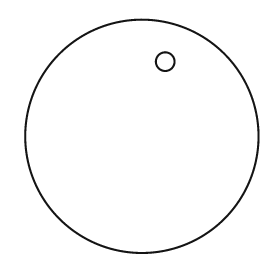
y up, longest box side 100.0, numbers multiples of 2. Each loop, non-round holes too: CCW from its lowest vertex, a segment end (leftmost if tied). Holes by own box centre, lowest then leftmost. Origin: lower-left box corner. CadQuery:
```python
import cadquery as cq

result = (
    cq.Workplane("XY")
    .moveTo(50.0, 50.0)
    .circle(50.0)
    .moveTo(60.0, 82.0)
    .circle(4.0)
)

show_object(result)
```